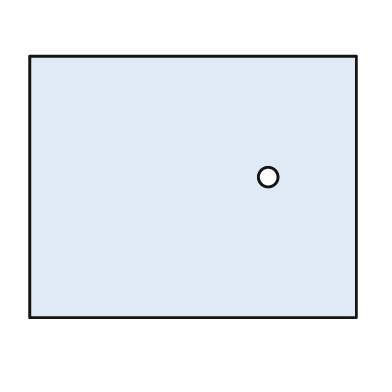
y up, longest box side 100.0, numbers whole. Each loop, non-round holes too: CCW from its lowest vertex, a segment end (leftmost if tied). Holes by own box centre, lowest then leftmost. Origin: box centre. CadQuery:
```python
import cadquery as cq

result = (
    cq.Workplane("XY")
    .moveTo(-50.0, -40.0)
    .lineTo(50.0, -40.0)
    .lineTo(50.0, 40.0)
    .lineTo(-50.0, 40.0)
    .close()
    .moveTo(23.0, 3.0)
    .circle(3.0)
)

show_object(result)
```